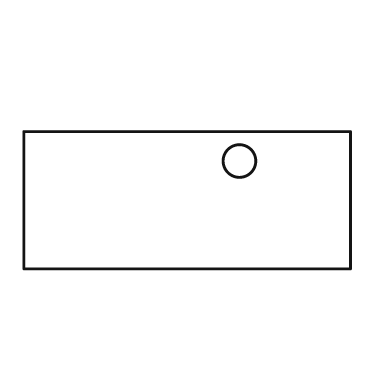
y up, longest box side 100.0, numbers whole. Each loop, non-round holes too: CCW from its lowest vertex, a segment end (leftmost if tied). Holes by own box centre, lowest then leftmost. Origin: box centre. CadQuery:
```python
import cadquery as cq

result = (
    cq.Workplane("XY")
    .moveTo(-50.0, -21.0)
    .lineTo(50.0, -21.0)
    .lineTo(50.0, 21.0)
    .lineTo(-50.0, 21.0)
    .close()
    .moveTo(16.0, 12.0)
    .circle(5.0)
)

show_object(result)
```